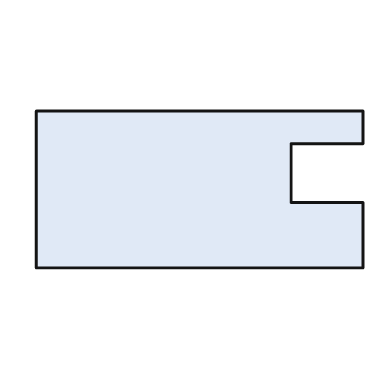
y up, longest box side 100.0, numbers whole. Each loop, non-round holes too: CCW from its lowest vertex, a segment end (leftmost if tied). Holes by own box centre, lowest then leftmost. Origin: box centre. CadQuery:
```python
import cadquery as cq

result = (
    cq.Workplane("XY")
    .moveTo(-50.0, -24.0)
    .lineTo(50.0, -24.0)
    .lineTo(50.0, -4.0)
    .lineTo(28.0, -4.0)
    .lineTo(28.0, 14.0)
    .lineTo(50.0, 14.0)
    .lineTo(50.0, 24.0)
    .lineTo(-50.0, 24.0)
    .close()
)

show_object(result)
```